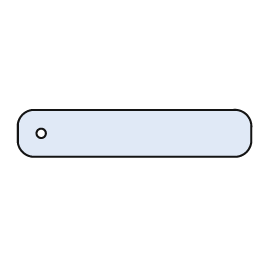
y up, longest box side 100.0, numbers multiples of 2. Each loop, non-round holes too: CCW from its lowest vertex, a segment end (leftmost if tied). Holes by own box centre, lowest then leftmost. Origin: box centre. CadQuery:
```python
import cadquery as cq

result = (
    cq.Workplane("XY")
    .moveTo(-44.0, -10.0)
    .lineTo(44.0, -10.0)
    .threePointArc((48.0, -8.0), (50.0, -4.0))
    .lineTo(50.0, 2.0)
    .threePointArc((48.0, 8.0), (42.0, 10.0))
    .lineTo(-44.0, 10.0)
    .threePointArc((-48.0, 8.0), (-50.0, 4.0))
    .lineTo(-50.0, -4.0)
    .threePointArc((-48.0, -8.0), (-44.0, -10.0))
    .close()
    .moveTo(-40.0, 0.0)
    .circle(2.0)
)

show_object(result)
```